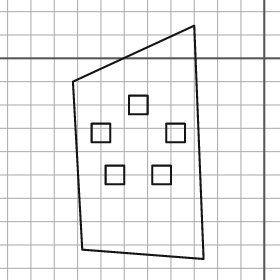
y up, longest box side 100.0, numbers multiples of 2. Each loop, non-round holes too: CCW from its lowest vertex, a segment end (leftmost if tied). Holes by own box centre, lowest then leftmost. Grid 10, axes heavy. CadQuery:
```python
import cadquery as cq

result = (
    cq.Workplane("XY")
    .moveTo(-26.0, -86.0)
    .lineTo(-30.0, 14.0)
    .lineTo(-82.0, -10.0)
    .lineTo(-78.0, -82.0)
    .close()
    .moveTo(-68.0, -54.0)
    .lineTo(-60.0, -54.0)
    .lineTo(-60.0, -46.0)
    .lineTo(-68.0, -46.0)
    .close()
    .moveTo(-48.0, -54.0)
    .lineTo(-40.0, -54.0)
    .lineTo(-40.0, -46.0)
    .lineTo(-48.0, -46.0)
    .close()
    .moveTo(-74.0, -36.0)
    .lineTo(-66.0, -36.0)
    .lineTo(-66.0, -28.0)
    .lineTo(-74.0, -28.0)
    .close()
    .moveTo(-42.0, -36.0)
    .lineTo(-34.0, -36.0)
    .lineTo(-34.0, -28.0)
    .lineTo(-42.0, -28.0)
    .close()
    .moveTo(-58.0, -24.0)
    .lineTo(-50.0, -24.0)
    .lineTo(-50.0, -16.0)
    .lineTo(-58.0, -16.0)
    .close()
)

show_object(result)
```